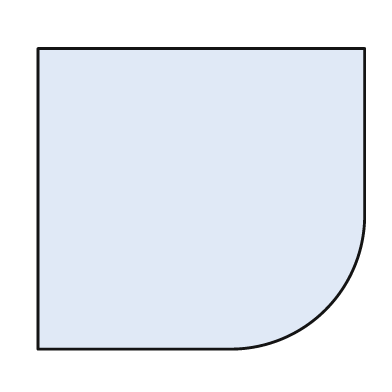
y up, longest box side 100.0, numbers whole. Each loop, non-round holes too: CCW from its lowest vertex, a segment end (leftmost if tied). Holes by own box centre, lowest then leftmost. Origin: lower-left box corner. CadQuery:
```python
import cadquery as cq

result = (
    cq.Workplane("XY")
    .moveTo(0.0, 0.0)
    .lineTo(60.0, 0.0)
    .threePointArc((88.0, 12.0), (100.0, 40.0))
    .lineTo(100.0, 92.0)
    .lineTo(0.0, 92.0)
    .close()
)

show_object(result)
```